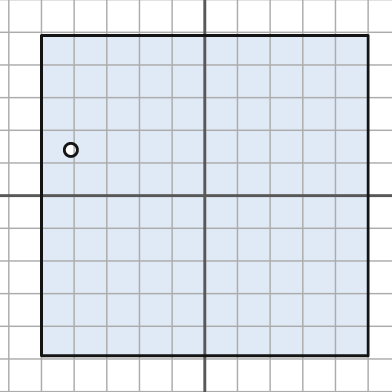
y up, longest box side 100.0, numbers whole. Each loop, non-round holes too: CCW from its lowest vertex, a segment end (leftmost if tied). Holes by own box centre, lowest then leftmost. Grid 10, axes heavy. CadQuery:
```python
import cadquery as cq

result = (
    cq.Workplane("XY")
    .moveTo(-50.0, -49.0)
    .lineTo(50.0, -49.0)
    .lineTo(50.0, 49.0)
    .lineTo(-50.0, 49.0)
    .close()
    .moveTo(-41.0, 14.0)
    .circle(2.0)
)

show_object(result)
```